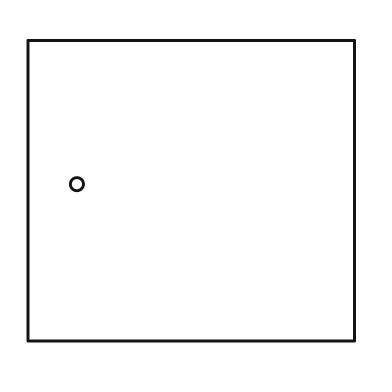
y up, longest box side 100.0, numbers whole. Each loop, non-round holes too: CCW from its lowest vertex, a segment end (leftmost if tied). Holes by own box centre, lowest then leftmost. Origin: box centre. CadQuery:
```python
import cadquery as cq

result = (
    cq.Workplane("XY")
    .moveTo(-50.0, -46.0)
    .lineTo(50.0, -46.0)
    .lineTo(50.0, 46.0)
    .lineTo(-50.0, 46.0)
    .close()
    .moveTo(-35.0, 2.0)
    .circle(2.0)
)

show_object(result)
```